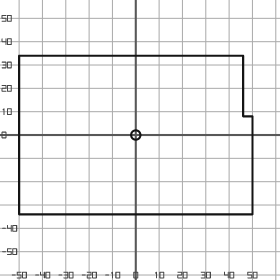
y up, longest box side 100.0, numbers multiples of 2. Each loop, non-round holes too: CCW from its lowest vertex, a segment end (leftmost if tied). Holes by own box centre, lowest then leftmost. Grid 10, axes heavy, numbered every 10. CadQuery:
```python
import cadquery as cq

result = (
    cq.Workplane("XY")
    .moveTo(-50.0, -34.0)
    .lineTo(50.0, -34.0)
    .lineTo(50.0, 8.0)
    .lineTo(46.0, 8.0)
    .lineTo(46.0, 34.0)
    .lineTo(-50.0, 34.0)
    .close()
    .moveTo(0.0, 0.0)
    .circle(2.0)
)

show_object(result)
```